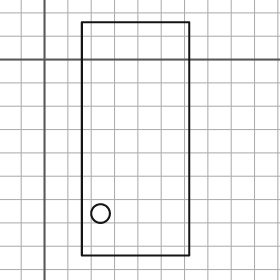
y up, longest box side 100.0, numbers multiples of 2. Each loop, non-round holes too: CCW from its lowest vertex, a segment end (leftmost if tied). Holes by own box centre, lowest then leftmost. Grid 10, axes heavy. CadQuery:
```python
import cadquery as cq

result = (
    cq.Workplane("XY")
    .moveTo(16.0, -84.0)
    .lineTo(62.0, -84.0)
    .lineTo(62.0, 16.0)
    .lineTo(16.0, 16.0)
    .close()
    .moveTo(24.0, -66.0)
    .circle(4.0)
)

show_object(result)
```